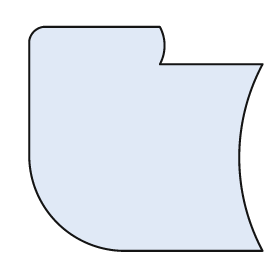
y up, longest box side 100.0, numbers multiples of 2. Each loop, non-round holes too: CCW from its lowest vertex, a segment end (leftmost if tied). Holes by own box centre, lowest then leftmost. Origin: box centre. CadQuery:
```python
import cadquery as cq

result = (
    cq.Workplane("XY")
    .moveTo(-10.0, -48.0)
    .lineTo(50.0, -48.0)
    .threePointArc((40.0, -8.0), (50.0, 32.0))
    .lineTo(6.0, 32.0)
    .threePointArc((8.0, 40.0), (6.0, 48.0))
    .lineTo(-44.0, 48.0)
    .threePointArc((-48.0, 46.0), (-50.0, 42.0))
    .lineTo(-50.0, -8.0)
    .threePointArc((-38.0, -36.0), (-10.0, -48.0))
    .close()
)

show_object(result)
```